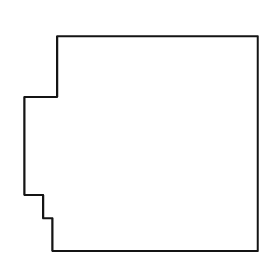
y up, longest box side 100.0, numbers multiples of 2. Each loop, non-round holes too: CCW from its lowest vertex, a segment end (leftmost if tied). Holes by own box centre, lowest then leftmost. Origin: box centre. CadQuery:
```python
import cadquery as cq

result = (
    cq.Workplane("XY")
    .moveTo(-38.0, -46.0)
    .lineTo(50.0, -46.0)
    .lineTo(50.0, 46.0)
    .lineTo(-36.0, 46.0)
    .lineTo(-36.0, 20.0)
    .lineTo(-50.0, 20.0)
    .lineTo(-50.0, -22.0)
    .lineTo(-42.0, -22.0)
    .lineTo(-42.0, -32.0)
    .lineTo(-38.0, -32.0)
    .close()
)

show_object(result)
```